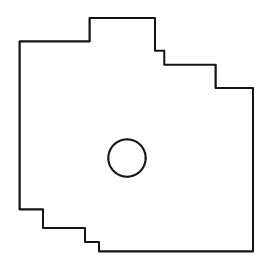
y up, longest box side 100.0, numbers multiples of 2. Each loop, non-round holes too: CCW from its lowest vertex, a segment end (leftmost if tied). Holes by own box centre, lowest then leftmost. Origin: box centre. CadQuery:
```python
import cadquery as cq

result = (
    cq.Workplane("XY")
    .moveTo(-16.0, -50.0)
    .lineTo(50.0, -50.0)
    .lineTo(50.0, 20.0)
    .lineTo(34.0, 20.0)
    .lineTo(34.0, 30.0)
    .lineTo(12.0, 30.0)
    .lineTo(12.0, 36.0)
    .lineTo(8.0, 36.0)
    .lineTo(8.0, 50.0)
    .lineTo(-20.0, 50.0)
    .lineTo(-20.0, 40.0)
    .lineTo(-50.0, 40.0)
    .lineTo(-50.0, -32.0)
    .lineTo(-40.0, -32.0)
    .lineTo(-40.0, -40.0)
    .lineTo(-22.0, -40.0)
    .lineTo(-22.0, -46.0)
    .lineTo(-16.0, -46.0)
    .close()
    .moveTo(-4.0, -10.0)
    .circle(8.0)
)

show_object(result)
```